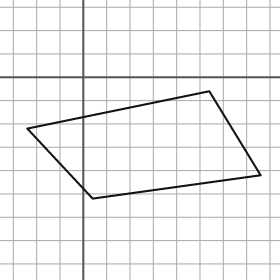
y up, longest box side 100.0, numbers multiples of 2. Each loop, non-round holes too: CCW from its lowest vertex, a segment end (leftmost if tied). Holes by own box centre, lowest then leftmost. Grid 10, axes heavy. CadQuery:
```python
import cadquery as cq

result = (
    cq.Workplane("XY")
    .moveTo(4.0, -52.0)
    .lineTo(76.0, -42.0)
    .lineTo(54.0, -6.0)
    .lineTo(-24.0, -22.0)
    .close()
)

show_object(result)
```